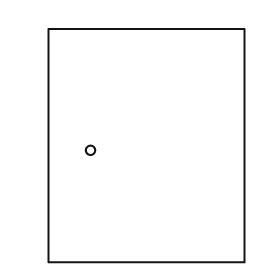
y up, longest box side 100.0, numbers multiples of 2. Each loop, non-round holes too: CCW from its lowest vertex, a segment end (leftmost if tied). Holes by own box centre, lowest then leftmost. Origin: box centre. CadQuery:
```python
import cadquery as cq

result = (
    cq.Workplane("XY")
    .moveTo(-42.0, -50.0)
    .lineTo(42.0, -50.0)
    .lineTo(42.0, 50.0)
    .lineTo(-42.0, 50.0)
    .close()
    .moveTo(-24.0, -2.0)
    .circle(2.0)
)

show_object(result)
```